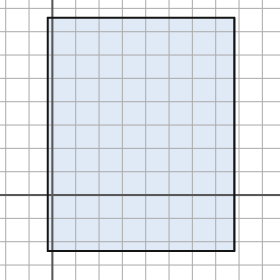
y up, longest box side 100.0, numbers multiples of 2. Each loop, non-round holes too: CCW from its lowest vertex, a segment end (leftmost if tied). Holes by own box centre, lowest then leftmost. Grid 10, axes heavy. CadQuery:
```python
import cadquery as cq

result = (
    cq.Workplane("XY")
    .moveTo(-2.0, -24.0)
    .lineTo(78.0, -24.0)
    .lineTo(78.0, 76.0)
    .lineTo(-2.0, 76.0)
    .close()
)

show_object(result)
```